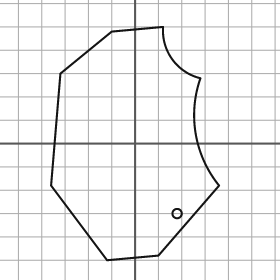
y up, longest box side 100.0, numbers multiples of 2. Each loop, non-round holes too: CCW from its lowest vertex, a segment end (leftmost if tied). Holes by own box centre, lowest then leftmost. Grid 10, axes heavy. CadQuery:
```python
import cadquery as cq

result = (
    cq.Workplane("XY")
    .moveTo(-12.0, -50.0)
    .lineTo(10.0, -48.0)
    .lineTo(36.0, -18.0)
    .threePointArc((26.0, 4.0), (28.0, 28.0))
    .threePointArc((16.0, 36.0), (12.0, 50.0))
    .lineTo(-10.0, 48.0)
    .lineTo(-32.0, 30.0)
    .lineTo(-36.0, -18.0)
    .close()
    .moveTo(18.0, -30.0)
    .circle(2.0)
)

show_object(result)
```